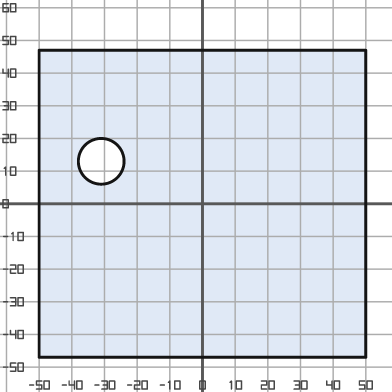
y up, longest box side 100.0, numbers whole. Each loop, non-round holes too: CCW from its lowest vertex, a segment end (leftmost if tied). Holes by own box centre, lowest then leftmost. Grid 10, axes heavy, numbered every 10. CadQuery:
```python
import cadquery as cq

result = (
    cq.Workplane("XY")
    .moveTo(-50.0, -47.0)
    .lineTo(50.0, -47.0)
    .lineTo(50.0, 47.0)
    .lineTo(-50.0, 47.0)
    .close()
    .moveTo(-31.0, 13.0)
    .circle(7.0)
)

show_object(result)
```